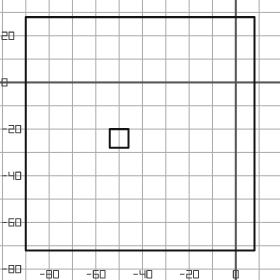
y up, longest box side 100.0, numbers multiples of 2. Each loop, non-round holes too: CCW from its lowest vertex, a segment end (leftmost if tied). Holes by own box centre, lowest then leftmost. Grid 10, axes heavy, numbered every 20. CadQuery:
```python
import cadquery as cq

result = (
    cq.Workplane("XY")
    .moveTo(-90.0, -72.0)
    .lineTo(8.0, -72.0)
    .lineTo(8.0, 28.0)
    .lineTo(-90.0, 28.0)
    .close()
    .moveTo(-54.0, -28.0)
    .lineTo(-46.0, -28.0)
    .lineTo(-46.0, -20.0)
    .lineTo(-54.0, -20.0)
    .close()
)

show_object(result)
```